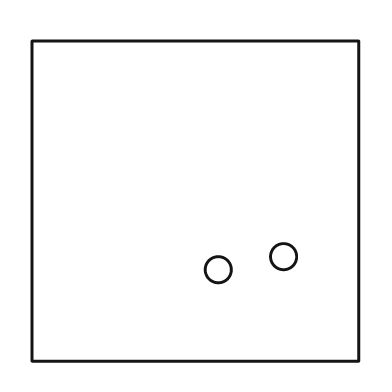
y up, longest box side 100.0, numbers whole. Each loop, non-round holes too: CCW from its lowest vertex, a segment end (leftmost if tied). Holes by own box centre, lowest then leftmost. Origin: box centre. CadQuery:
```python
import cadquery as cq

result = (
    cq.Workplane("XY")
    .moveTo(-50.0, -49.0)
    .lineTo(50.0, -49.0)
    .lineTo(50.0, 49.0)
    .lineTo(-50.0, 49.0)
    .close()
    .moveTo(7.0, -21.0)
    .circle(4.0)
    .moveTo(27.0, -17.0)
    .circle(4.0)
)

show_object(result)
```